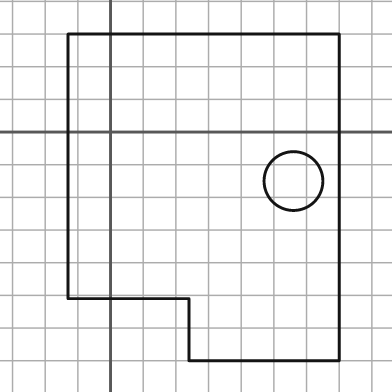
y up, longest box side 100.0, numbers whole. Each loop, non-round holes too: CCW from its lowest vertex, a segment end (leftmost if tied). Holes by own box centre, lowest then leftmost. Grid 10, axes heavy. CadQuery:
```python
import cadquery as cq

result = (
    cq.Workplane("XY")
    .moveTo(24.0, -70.0)
    .lineTo(70.0, -70.0)
    .lineTo(70.0, 30.0)
    .lineTo(-13.0, 30.0)
    .lineTo(-13.0, -51.0)
    .lineTo(24.0, -51.0)
    .close()
    .moveTo(56.0, -15.0)
    .circle(9.0)
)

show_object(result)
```